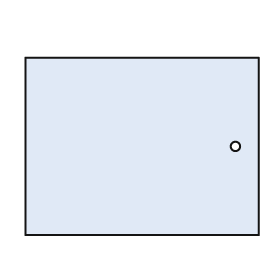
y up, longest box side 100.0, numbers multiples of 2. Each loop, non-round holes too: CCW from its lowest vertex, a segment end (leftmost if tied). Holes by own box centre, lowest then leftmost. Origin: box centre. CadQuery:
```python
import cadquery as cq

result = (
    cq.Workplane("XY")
    .moveTo(-50.0, -38.0)
    .lineTo(50.0, -38.0)
    .lineTo(50.0, 38.0)
    .lineTo(-50.0, 38.0)
    .close()
    .moveTo(40.0, 0.0)
    .circle(2.0)
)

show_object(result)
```